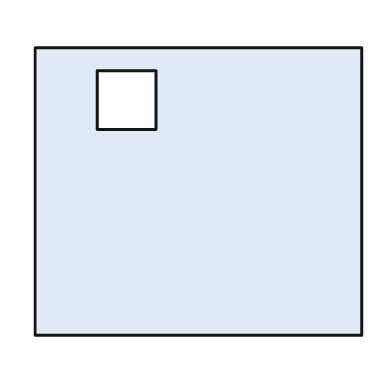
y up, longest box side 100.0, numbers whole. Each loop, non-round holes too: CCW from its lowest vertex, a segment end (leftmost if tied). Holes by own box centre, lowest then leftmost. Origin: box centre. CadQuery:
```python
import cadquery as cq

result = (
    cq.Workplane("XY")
    .moveTo(-50.0, -44.0)
    .lineTo(50.0, -44.0)
    .lineTo(50.0, 44.0)
    .lineTo(-50.0, 44.0)
    .close()
    .moveTo(-31.0, 19.0)
    .lineTo(-13.0, 19.0)
    .lineTo(-13.0, 37.0)
    .lineTo(-31.0, 37.0)
    .close()
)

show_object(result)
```